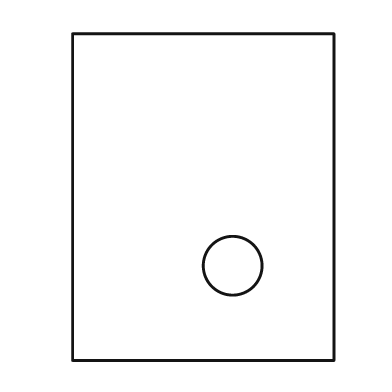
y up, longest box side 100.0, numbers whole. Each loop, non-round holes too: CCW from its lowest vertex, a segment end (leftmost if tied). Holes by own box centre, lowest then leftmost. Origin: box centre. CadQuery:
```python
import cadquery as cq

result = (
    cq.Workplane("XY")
    .moveTo(-40.0, -50.0)
    .lineTo(40.0, -50.0)
    .lineTo(40.0, 50.0)
    .lineTo(-40.0, 50.0)
    .close()
    .moveTo(9.0, -21.0)
    .circle(9.0)
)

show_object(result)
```